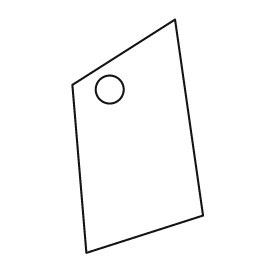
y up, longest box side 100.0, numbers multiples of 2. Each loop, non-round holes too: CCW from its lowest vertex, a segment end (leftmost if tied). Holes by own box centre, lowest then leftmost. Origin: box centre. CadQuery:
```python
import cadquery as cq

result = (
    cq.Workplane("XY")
    .moveTo(-22.0, -50.0)
    .lineTo(28.0, -34.0)
    .lineTo(16.0, 50.0)
    .lineTo(-28.0, 22.0)
    .close()
    .moveTo(-12.0, 20.0)
    .circle(6.0)
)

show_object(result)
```